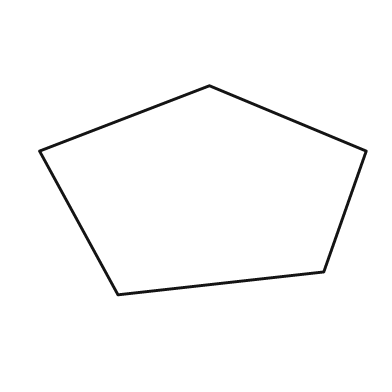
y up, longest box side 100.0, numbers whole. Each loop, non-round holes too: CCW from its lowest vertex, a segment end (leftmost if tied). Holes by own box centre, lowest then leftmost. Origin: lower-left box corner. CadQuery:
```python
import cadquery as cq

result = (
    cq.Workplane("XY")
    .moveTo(24.0, 0.0)
    .lineTo(87.0, 7.0)
    .lineTo(100.0, 44.0)
    .lineTo(52.0, 64.0)
    .lineTo(0.0, 44.0)
    .close()
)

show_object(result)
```